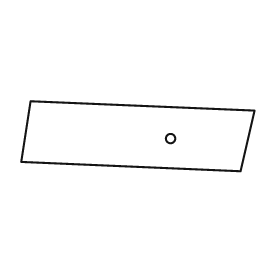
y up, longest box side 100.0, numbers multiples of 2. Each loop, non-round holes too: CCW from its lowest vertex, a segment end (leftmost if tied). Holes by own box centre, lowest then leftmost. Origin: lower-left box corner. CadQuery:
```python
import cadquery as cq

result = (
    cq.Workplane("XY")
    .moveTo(94.0, 0.0)
    .lineTo(100.0, 26.0)
    .lineTo(4.0, 30.0)
    .lineTo(0.0, 4.0)
    .close()
    .moveTo(64.0, 14.0)
    .circle(2.0)
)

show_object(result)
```